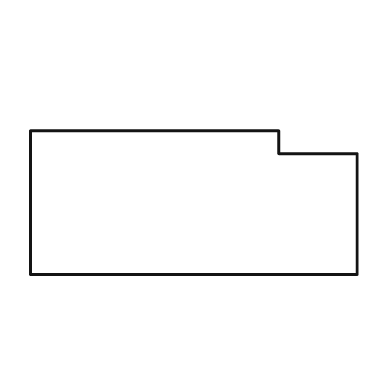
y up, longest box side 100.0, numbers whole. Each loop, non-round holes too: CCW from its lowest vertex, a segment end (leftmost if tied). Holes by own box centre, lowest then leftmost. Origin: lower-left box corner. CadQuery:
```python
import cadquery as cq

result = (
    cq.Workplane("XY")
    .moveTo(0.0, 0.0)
    .lineTo(100.0, 0.0)
    .lineTo(100.0, 37.0)
    .lineTo(76.0, 37.0)
    .lineTo(76.0, 44.0)
    .lineTo(0.0, 44.0)
    .close()
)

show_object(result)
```